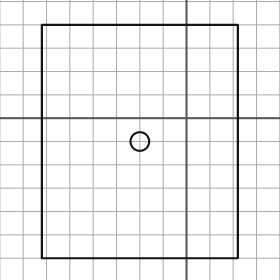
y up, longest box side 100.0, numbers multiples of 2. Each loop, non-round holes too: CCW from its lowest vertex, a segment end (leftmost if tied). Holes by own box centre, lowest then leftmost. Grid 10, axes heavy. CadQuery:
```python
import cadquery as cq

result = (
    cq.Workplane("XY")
    .moveTo(-62.0, -60.0)
    .lineTo(22.0, -60.0)
    .lineTo(22.0, 40.0)
    .lineTo(-62.0, 40.0)
    .close()
    .moveTo(-20.0, -10.0)
    .circle(4.0)
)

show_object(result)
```